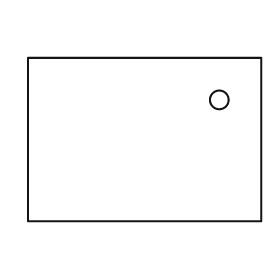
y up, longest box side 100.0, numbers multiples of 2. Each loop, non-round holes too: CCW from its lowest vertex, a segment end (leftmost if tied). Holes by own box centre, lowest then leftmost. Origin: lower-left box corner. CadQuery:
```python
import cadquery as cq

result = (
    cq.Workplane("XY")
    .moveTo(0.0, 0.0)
    .lineTo(100.0, 0.0)
    .lineTo(100.0, 70.0)
    .lineTo(0.0, 70.0)
    .close()
    .moveTo(82.0, 52.0)
    .circle(4.0)
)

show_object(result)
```